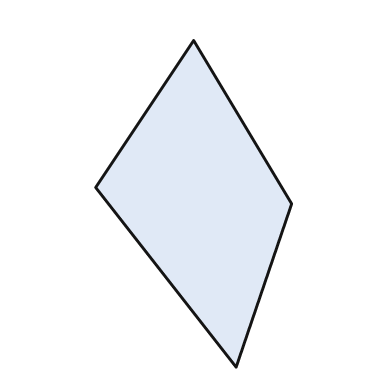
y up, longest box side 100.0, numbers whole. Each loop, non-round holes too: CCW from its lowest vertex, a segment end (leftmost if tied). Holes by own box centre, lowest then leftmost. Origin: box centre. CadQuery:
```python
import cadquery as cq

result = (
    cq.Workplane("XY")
    .moveTo(13.0, -50.0)
    .lineTo(30.0, 0.0)
    .lineTo(0.0, 50.0)
    .lineTo(-30.0, 5.0)
    .close()
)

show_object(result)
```